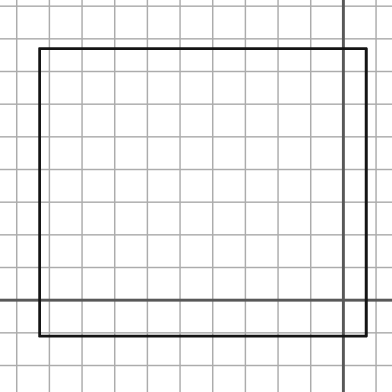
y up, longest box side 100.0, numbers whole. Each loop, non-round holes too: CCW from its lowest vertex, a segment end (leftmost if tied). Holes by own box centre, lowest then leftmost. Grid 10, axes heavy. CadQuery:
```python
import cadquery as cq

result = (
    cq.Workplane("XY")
    .moveTo(-93.0, -11.0)
    .lineTo(7.0, -11.0)
    .lineTo(7.0, 77.0)
    .lineTo(-93.0, 77.0)
    .close()
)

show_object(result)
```